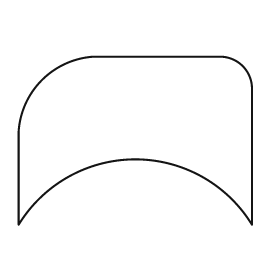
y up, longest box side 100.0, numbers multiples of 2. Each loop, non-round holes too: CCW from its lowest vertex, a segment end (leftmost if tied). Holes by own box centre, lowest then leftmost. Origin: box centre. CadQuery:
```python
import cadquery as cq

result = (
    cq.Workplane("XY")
    .moveTo(-50.0, -36.0)
    .threePointArc((0.0, -8.0), (50.0, -36.0))
    .lineTo(50.0, 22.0)
    .threePointArc((46.0, 32.0), (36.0, 36.0))
    .lineTo(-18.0, 36.0)
    .threePointArc((-40.0, 26.0), (-50.0, 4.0))
    .close()
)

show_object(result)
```